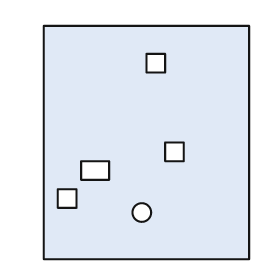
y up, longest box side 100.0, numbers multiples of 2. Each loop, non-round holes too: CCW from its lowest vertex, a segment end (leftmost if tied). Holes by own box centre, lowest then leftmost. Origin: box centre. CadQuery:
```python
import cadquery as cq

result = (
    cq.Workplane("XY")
    .moveTo(-44.0, -50.0)
    .lineTo(44.0, -50.0)
    .lineTo(44.0, 50.0)
    .lineTo(-44.0, 50.0)
    .close()
    .moveTo(-2.0, -30.0)
    .circle(4.0)
    .moveTo(-38.0, -28.0)
    .lineTo(-30.0, -28.0)
    .lineTo(-30.0, -20.0)
    .lineTo(-38.0, -20.0)
    .close()
    .moveTo(-28.0, -16.0)
    .lineTo(-16.0, -16.0)
    .lineTo(-16.0, -8.0)
    .lineTo(-28.0, -8.0)
    .close()
    .moveTo(8.0, -8.0)
    .lineTo(16.0, -8.0)
    .lineTo(16.0, 0.0)
    .lineTo(8.0, 0.0)
    .close()
    .moveTo(0.0, 30.0)
    .lineTo(8.0, 30.0)
    .lineTo(8.0, 38.0)
    .lineTo(0.0, 38.0)
    .close()
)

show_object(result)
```